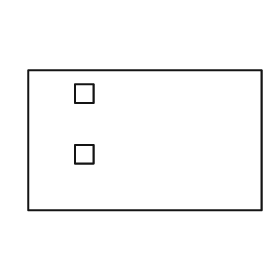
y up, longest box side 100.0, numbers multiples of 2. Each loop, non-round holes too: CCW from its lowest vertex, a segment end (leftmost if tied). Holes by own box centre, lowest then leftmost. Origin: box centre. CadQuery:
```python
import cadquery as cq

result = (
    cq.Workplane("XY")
    .moveTo(-50.0, -30.0)
    .lineTo(50.0, -30.0)
    .lineTo(50.0, 30.0)
    .lineTo(-50.0, 30.0)
    .close()
    .moveTo(-30.0, -10.0)
    .lineTo(-22.0, -10.0)
    .lineTo(-22.0, -2.0)
    .lineTo(-30.0, -2.0)
    .close()
    .moveTo(-30.0, 16.0)
    .lineTo(-22.0, 16.0)
    .lineTo(-22.0, 24.0)
    .lineTo(-30.0, 24.0)
    .close()
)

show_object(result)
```